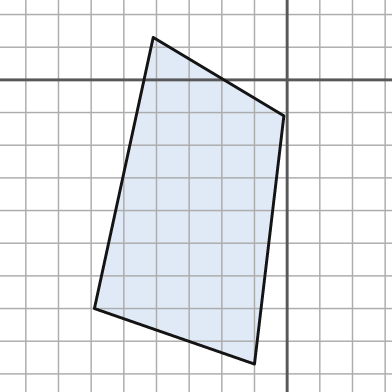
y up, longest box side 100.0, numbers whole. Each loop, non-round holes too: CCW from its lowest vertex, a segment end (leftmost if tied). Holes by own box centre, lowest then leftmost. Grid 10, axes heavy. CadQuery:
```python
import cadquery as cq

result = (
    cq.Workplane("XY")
    .moveTo(-10.0, -87.0)
    .lineTo(-1.0, -11.0)
    .lineTo(-41.0, 13.0)
    .lineTo(-59.0, -70.0)
    .close()
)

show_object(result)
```